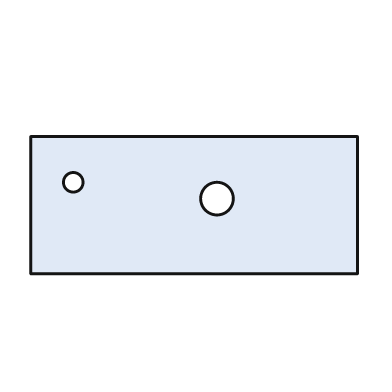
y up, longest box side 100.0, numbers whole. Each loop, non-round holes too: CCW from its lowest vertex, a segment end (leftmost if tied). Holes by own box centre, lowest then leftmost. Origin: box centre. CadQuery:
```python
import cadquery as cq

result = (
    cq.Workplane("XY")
    .moveTo(-50.0, -21.0)
    .lineTo(50.0, -21.0)
    .lineTo(50.0, 21.0)
    .lineTo(-50.0, 21.0)
    .close()
    .moveTo(7.0, 2.0)
    .circle(5.0)
    .moveTo(-37.0, 7.0)
    .circle(3.0)
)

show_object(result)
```